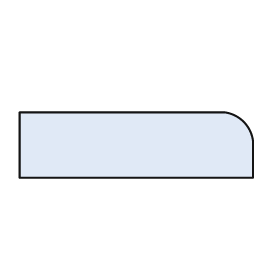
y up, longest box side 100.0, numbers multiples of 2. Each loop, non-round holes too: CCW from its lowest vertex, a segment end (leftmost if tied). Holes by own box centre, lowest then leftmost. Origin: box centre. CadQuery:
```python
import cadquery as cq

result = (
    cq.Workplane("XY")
    .moveTo(-50.0, -14.0)
    .lineTo(50.0, -14.0)
    .lineTo(50.0, 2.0)
    .threePointArc((46.0, 10.0), (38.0, 14.0))
    .lineTo(-50.0, 14.0)
    .close()
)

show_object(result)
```